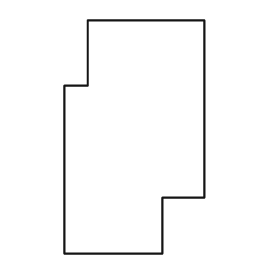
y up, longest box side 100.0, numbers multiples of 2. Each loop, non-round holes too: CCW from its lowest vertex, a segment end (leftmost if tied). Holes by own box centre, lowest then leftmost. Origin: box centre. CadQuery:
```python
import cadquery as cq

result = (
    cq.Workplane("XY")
    .moveTo(-30.0, -50.0)
    .lineTo(12.0, -50.0)
    .lineTo(12.0, -26.0)
    .lineTo(30.0, -26.0)
    .lineTo(30.0, 50.0)
    .lineTo(-20.0, 50.0)
    .lineTo(-20.0, 22.0)
    .lineTo(-30.0, 22.0)
    .close()
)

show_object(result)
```